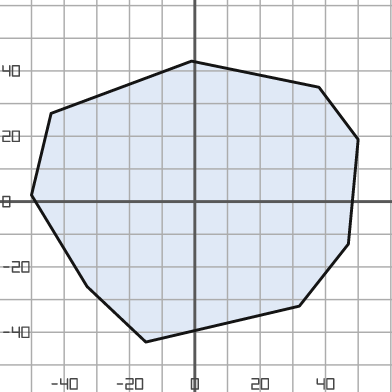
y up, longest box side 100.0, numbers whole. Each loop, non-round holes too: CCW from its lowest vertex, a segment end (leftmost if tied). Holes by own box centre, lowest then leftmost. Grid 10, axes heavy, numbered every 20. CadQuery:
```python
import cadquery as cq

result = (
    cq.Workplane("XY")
    .moveTo(-15.0, -43.0)
    .lineTo(32.0, -32.0)
    .lineTo(47.0, -13.0)
    .lineTo(50.0, 19.0)
    .lineTo(38.0, 35.0)
    .lineTo(-1.0, 43.0)
    .lineTo(-44.0, 27.0)
    .lineTo(-50.0, 2.0)
    .lineTo(-33.0, -26.0)
    .close()
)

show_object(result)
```